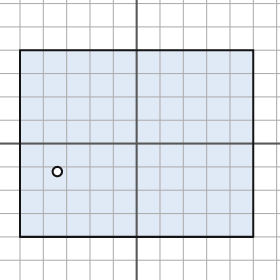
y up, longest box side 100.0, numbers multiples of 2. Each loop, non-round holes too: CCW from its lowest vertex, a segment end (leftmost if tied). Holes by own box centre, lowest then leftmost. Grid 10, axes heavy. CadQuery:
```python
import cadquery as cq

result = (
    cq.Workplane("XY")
    .moveTo(-50.0, -40.0)
    .lineTo(50.0, -40.0)
    .lineTo(50.0, 40.0)
    .lineTo(-50.0, 40.0)
    .close()
    .moveTo(-34.0, -12.0)
    .circle(2.0)
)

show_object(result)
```